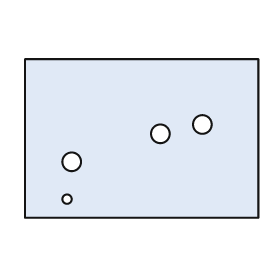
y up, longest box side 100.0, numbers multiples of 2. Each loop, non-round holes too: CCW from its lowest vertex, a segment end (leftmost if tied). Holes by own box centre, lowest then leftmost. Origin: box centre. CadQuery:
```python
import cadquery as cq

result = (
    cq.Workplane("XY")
    .moveTo(-50.0, -34.0)
    .lineTo(50.0, -34.0)
    .lineTo(50.0, 34.0)
    .lineTo(-50.0, 34.0)
    .close()
    .moveTo(-32.0, -26.0)
    .circle(2.0)
    .moveTo(-30.0, -10.0)
    .circle(4.0)
    .moveTo(8.0, 2.0)
    .circle(4.0)
    .moveTo(26.0, 6.0)
    .circle(4.0)
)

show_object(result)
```